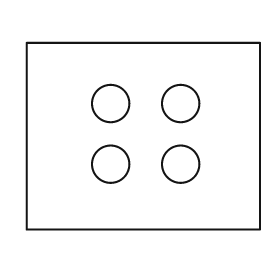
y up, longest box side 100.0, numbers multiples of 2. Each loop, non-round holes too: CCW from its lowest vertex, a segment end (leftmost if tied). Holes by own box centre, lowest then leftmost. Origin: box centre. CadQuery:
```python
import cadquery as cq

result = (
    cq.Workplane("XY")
    .moveTo(-50.0, -40.0)
    .lineTo(50.0, -40.0)
    .lineTo(50.0, 40.0)
    .lineTo(-50.0, 40.0)
    .close()
    .moveTo(-14.0, -12.0)
    .circle(8.0)
    .moveTo(16.0, -12.0)
    .circle(8.0)
    .moveTo(-14.0, 14.0)
    .circle(8.0)
    .moveTo(16.0, 14.0)
    .circle(8.0)
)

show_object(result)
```